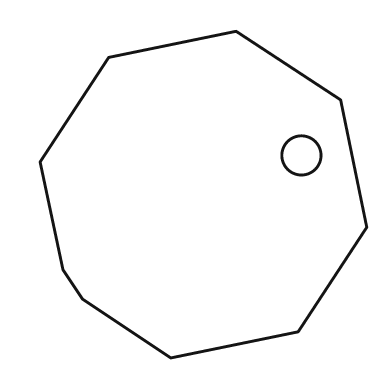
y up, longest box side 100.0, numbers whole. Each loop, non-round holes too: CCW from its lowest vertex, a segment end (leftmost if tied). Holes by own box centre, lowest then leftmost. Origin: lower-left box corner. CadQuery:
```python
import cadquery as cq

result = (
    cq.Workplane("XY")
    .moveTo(40.0, 0.0)
    .lineTo(79.0, 8.0)
    .lineTo(100.0, 40.0)
    .lineTo(92.0, 79.0)
    .lineTo(60.0, 100.0)
    .lineTo(21.0, 92.0)
    .lineTo(0.0, 60.0)
    .lineTo(7.0, 27.0)
    .lineTo(13.0, 18.0)
    .close()
    .moveTo(80.0, 62.0)
    .circle(6.0)
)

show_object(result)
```